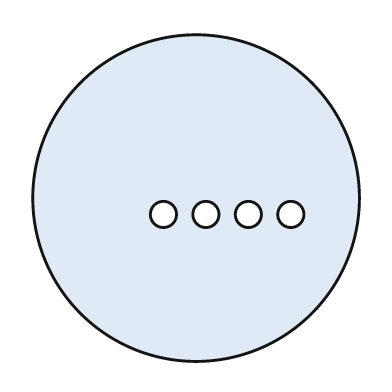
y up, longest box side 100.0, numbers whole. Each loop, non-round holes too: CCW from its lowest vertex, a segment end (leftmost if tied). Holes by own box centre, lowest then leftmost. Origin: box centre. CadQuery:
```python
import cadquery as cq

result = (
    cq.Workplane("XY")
    .moveTo(0.0, 0.0)
    .circle(50.0)
    .moveTo(-10.0, -5.0)
    .circle(4.0)
    .moveTo(3.0, -5.0)
    .circle(4.0)
    .moveTo(16.0, -5.0)
    .circle(4.0)
    .moveTo(29.0, -5.0)
    .circle(4.0)
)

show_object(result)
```